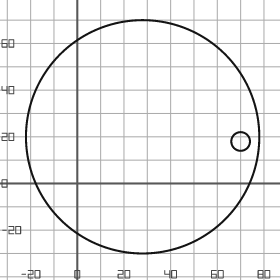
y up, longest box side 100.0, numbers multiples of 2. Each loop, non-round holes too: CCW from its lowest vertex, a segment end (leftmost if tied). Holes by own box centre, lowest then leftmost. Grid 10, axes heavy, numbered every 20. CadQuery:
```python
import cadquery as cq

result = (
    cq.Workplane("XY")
    .moveTo(28.0, 20.0)
    .circle(50.0)
    .moveTo(70.0, 18.0)
    .circle(4.0)
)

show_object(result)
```